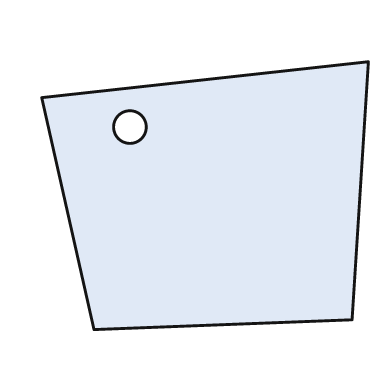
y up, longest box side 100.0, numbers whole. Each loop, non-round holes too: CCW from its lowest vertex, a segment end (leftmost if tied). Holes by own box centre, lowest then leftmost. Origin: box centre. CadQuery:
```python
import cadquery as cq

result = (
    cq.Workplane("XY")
    .moveTo(-34.0, -41.0)
    .lineTo(45.0, -38.0)
    .lineTo(50.0, 41.0)
    .lineTo(-50.0, 30.0)
    .close()
    .moveTo(-23.0, 21.0)
    .circle(5.0)
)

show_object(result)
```